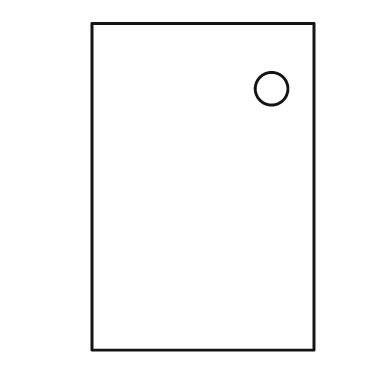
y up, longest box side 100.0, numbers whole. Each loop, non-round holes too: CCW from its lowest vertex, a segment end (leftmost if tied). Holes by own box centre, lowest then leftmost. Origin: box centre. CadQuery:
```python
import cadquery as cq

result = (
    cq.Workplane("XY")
    .moveTo(-34.0, -50.0)
    .lineTo(34.0, -50.0)
    .lineTo(34.0, 50.0)
    .lineTo(-34.0, 50.0)
    .close()
    .moveTo(21.0, 30.0)
    .circle(5.0)
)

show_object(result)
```